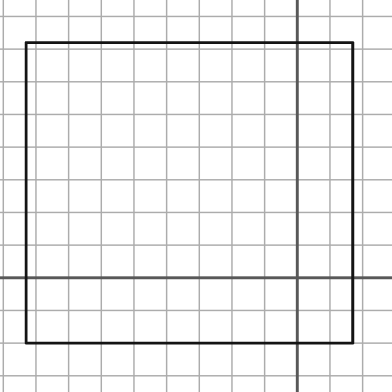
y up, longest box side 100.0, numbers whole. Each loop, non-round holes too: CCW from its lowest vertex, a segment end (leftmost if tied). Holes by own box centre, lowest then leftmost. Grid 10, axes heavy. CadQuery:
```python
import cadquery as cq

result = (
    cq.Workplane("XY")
    .moveTo(-83.0, -20.0)
    .lineTo(17.0, -20.0)
    .lineTo(17.0, 72.0)
    .lineTo(-83.0, 72.0)
    .close()
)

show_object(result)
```